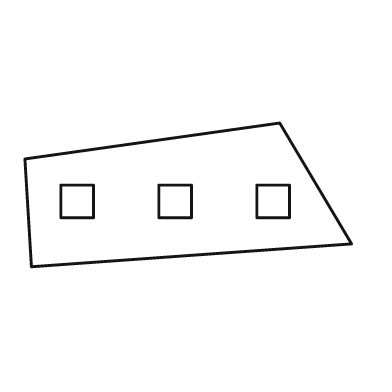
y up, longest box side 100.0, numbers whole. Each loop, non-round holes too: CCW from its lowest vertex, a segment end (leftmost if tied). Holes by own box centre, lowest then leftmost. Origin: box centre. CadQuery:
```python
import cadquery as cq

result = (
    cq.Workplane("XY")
    .moveTo(-48.0, -22.0)
    .lineTo(50.0, -15.0)
    .lineTo(28.0, 22.0)
    .lineTo(-50.0, 11.0)
    .close()
    .moveTo(-39.0, -7.0)
    .lineTo(-29.0, -7.0)
    .lineTo(-29.0, 3.0)
    .lineTo(-39.0, 3.0)
    .close()
    .moveTo(-9.0, -7.0)
    .lineTo(1.0, -7.0)
    .lineTo(1.0, 3.0)
    .lineTo(-9.0, 3.0)
    .close()
    .moveTo(21.0, -7.0)
    .lineTo(31.0, -7.0)
    .lineTo(31.0, 3.0)
    .lineTo(21.0, 3.0)
    .close()
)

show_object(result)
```